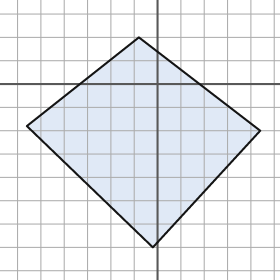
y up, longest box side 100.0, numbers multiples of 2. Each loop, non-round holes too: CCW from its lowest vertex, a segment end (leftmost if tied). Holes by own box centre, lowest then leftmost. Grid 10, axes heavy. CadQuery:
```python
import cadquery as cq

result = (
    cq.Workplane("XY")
    .moveTo(-2.0, -70.0)
    .lineTo(44.0, -20.0)
    .lineTo(-8.0, 20.0)
    .lineTo(-56.0, -18.0)
    .close()
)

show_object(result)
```